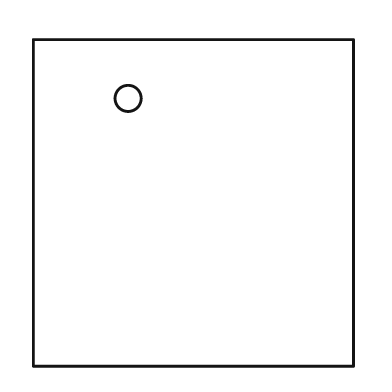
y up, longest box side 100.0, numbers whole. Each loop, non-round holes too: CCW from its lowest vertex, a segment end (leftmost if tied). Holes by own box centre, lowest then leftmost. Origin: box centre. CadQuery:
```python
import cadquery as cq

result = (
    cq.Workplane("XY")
    .moveTo(-49.0, -50.0)
    .lineTo(49.0, -50.0)
    .lineTo(49.0, 50.0)
    .lineTo(-49.0, 50.0)
    .close()
    .moveTo(-20.0, 32.0)
    .circle(4.0)
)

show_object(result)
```